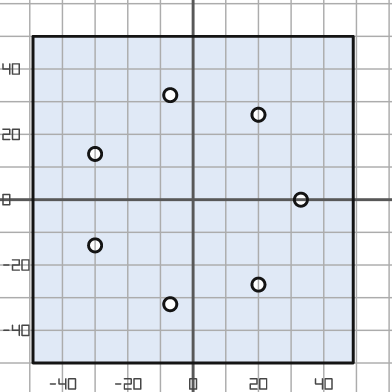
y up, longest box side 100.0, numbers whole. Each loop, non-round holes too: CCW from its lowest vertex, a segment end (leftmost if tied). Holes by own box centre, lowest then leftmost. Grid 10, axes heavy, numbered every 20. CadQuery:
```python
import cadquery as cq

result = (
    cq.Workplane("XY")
    .moveTo(-49.0, -50.0)
    .lineTo(49.0, -50.0)
    .lineTo(49.0, 50.0)
    .lineTo(-49.0, 50.0)
    .close()
    .moveTo(-7.0, -32.0)
    .circle(2.0)
    .moveTo(20.0, -26.0)
    .circle(2.0)
    .moveTo(-30.0, -14.0)
    .circle(2.0)
    .moveTo(33.0, 0.0)
    .circle(2.0)
    .moveTo(-30.0, 14.0)
    .circle(2.0)
    .moveTo(20.0, 26.0)
    .circle(2.0)
    .moveTo(-7.0, 32.0)
    .circle(2.0)
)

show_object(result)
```